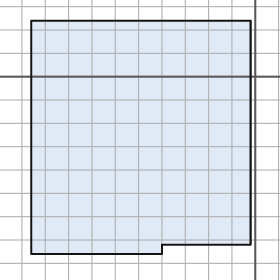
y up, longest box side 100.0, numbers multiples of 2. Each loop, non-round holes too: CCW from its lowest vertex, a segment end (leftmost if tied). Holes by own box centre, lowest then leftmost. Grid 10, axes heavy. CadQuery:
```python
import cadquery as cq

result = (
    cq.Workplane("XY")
    .moveTo(-96.0, -76.0)
    .lineTo(-40.0, -76.0)
    .lineTo(-40.0, -72.0)
    .lineTo(-2.0, -72.0)
    .lineTo(-2.0, 24.0)
    .lineTo(-96.0, 24.0)
    .close()
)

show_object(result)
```